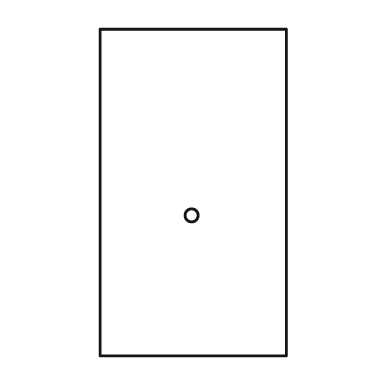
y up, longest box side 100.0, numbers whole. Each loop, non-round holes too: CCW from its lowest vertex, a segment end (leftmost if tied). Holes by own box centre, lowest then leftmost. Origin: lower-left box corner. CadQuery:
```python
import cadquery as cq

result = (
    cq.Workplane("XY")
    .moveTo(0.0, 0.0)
    .lineTo(57.0, 0.0)
    .lineTo(57.0, 100.0)
    .lineTo(0.0, 100.0)
    .close()
    .moveTo(28.0, 43.0)
    .circle(2.0)
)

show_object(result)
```